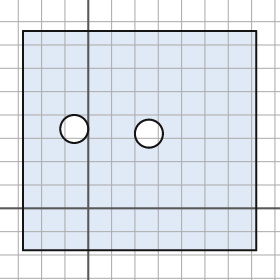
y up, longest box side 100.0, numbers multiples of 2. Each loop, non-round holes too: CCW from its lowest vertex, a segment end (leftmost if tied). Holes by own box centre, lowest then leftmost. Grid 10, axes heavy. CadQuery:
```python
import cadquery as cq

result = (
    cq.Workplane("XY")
    .moveTo(-28.0, -18.0)
    .lineTo(72.0, -18.0)
    .lineTo(72.0, 76.0)
    .lineTo(-28.0, 76.0)
    .close()
    .moveTo(26.0, 32.0)
    .circle(6.0)
    .moveTo(-6.0, 34.0)
    .circle(6.0)
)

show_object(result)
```